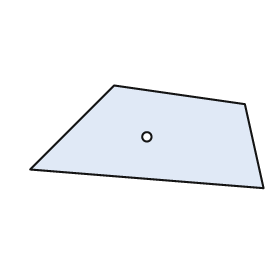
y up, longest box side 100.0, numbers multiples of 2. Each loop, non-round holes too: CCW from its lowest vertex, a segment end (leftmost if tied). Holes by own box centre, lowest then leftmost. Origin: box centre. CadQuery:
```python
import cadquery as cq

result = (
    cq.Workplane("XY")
    .moveTo(50.0, -22.0)
    .lineTo(42.0, 14.0)
    .lineTo(-14.0, 22.0)
    .lineTo(-50.0, -14.0)
    .close()
    .moveTo(0.0, 0.0)
    .circle(2.0)
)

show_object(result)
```